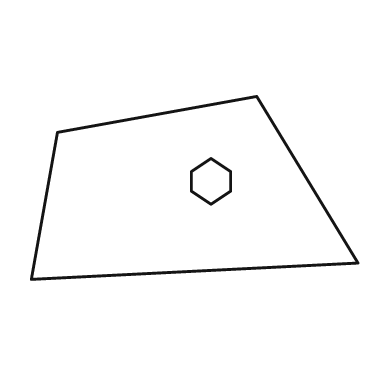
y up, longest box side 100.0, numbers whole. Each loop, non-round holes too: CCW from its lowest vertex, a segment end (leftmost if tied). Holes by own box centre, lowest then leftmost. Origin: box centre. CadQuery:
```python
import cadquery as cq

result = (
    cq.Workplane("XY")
    .moveTo(-50.0, -28.0)
    .lineTo(50.0, -23.0)
    .lineTo(19.0, 28.0)
    .lineTo(-42.0, 17.0)
    .close()
    .moveTo(5.0, -5.0)
    .lineTo(11.0, -1.0)
    .lineTo(11.0, 5.0)
    .lineTo(5.0, 9.0)
    .lineTo(-1.0, 5.0)
    .lineTo(-1.0, -1.0)
    .close()
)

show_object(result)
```